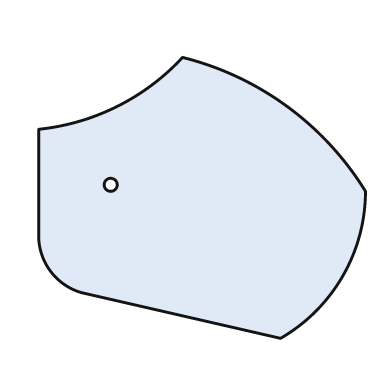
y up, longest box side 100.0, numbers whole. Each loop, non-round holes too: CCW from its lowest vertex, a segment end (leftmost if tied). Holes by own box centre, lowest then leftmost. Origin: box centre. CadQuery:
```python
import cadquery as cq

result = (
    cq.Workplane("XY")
    .moveTo(24.0, -43.0)
    .threePointArc((43.0, -24.0), (50.0, 2.0))
    .threePointArc((26.0, 28.0), (-6.0, 43.0))
    .threePointArc((-26.0, 28.0), (-50.0, 21.0))
    .lineTo(-50.0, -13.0)
    .threePointArc((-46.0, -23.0), (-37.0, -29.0))
    .close()
    .moveTo(-28.0, 4.0)
    .circle(2.0)
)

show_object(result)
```